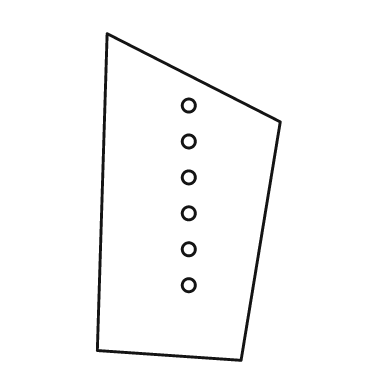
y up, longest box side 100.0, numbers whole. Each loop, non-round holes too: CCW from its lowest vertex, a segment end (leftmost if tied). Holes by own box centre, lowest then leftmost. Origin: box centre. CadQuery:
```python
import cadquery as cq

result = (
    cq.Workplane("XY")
    .moveTo(16.0, -50.0)
    .lineTo(28.0, 23.0)
    .lineTo(-25.0, 50.0)
    .lineTo(-28.0, -47.0)
    .close()
    .moveTo(0.0, -27.0)
    .circle(2.0)
    .moveTo(0.0, -16.0)
    .circle(2.0)
    .moveTo(0.0, -5.0)
    .circle(2.0)
    .moveTo(0.0, 6.0)
    .circle(2.0)
    .moveTo(0.0, 17.0)
    .circle(2.0)
    .moveTo(0.0, 28.0)
    .circle(2.0)
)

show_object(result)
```